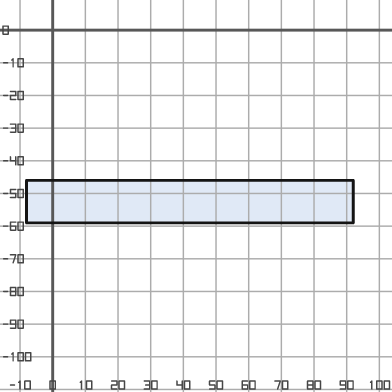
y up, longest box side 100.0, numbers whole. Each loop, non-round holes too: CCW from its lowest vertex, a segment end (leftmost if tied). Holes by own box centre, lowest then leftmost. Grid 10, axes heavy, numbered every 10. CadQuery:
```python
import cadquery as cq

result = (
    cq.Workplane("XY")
    .moveTo(-8.0, -59.0)
    .lineTo(92.0, -59.0)
    .lineTo(92.0, -46.0)
    .lineTo(-8.0, -46.0)
    .close()
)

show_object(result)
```